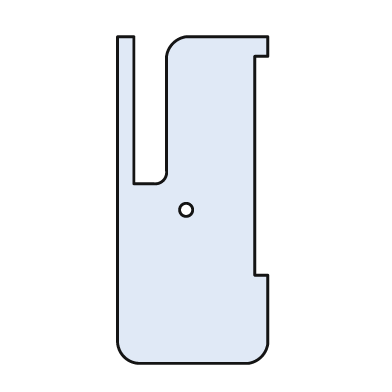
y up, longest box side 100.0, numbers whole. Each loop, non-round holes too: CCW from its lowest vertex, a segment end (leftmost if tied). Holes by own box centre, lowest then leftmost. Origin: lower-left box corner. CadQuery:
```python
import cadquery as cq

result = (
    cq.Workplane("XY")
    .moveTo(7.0, 0.0)
    .lineTo(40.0, 0.0)
    .threePointArc((44.0, 2.0), (46.0, 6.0))
    .lineTo(46.0, 27.0)
    .lineTo(42.0, 27.0)
    .lineTo(42.0, 94.0)
    .lineTo(46.0, 94.0)
    .lineTo(46.0, 100.0)
    .lineTo(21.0, 100.0)
    .threePointArc((17.0, 98.0), (15.0, 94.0))
    .lineTo(15.0, 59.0)
    .threePointArc((14.0, 56.0), (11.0, 55.0))
    .lineTo(5.0, 55.0)
    .lineTo(5.0, 100.0)
    .lineTo(0.0, 100.0)
    .lineTo(0.0, 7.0)
    .threePointArc((2.0, 2.0), (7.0, 0.0))
    .close()
    .moveTo(21.0, 47.0)
    .circle(2.0)
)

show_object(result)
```